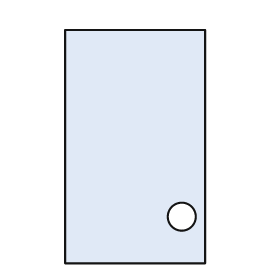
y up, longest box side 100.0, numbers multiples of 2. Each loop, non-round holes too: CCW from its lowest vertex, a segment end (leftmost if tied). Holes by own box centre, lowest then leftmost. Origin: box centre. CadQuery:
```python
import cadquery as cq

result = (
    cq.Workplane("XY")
    .moveTo(-30.0, -50.0)
    .lineTo(30.0, -50.0)
    .lineTo(30.0, 50.0)
    .lineTo(-30.0, 50.0)
    .close()
    .moveTo(20.0, -30.0)
    .circle(6.0)
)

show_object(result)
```